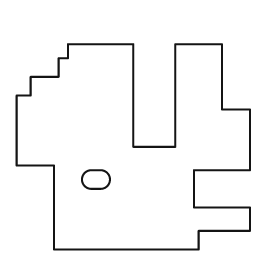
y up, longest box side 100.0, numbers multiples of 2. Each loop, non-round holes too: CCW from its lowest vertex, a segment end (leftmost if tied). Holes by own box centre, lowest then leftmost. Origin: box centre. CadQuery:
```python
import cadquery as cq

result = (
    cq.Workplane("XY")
    .moveTo(-34.0, -44.0)
    .lineTo(28.0, -44.0)
    .lineTo(28.0, -36.0)
    .lineTo(50.0, -36.0)
    .lineTo(50.0, -26.0)
    .lineTo(26.0, -26.0)
    .lineTo(26.0, -10.0)
    .lineTo(50.0, -10.0)
    .lineTo(50.0, 16.0)
    .lineTo(38.0, 16.0)
    .lineTo(38.0, 44.0)
    .lineTo(18.0, 44.0)
    .lineTo(18.0, 0.0)
    .lineTo(0.0, 0.0)
    .lineTo(0.0, 44.0)
    .lineTo(-28.0, 44.0)
    .lineTo(-28.0, 38.0)
    .lineTo(-32.0, 38.0)
    .lineTo(-32.0, 30.0)
    .lineTo(-44.0, 30.0)
    .lineTo(-44.0, 22.0)
    .lineTo(-50.0, 22.0)
    .lineTo(-50.0, -8.0)
    .lineTo(-34.0, -8.0)
    .close()
    .moveTo(-18.0, -18.0)
    .lineTo(-14.0, -18.0)
    .threePointArc((-10.0, -14.0), (-14.0, -10.0))
    .lineTo(-18.0, -10.0)
    .threePointArc((-22.0, -14.0), (-18.0, -18.0))
    .close()
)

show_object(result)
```